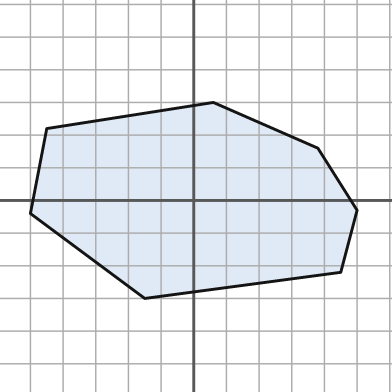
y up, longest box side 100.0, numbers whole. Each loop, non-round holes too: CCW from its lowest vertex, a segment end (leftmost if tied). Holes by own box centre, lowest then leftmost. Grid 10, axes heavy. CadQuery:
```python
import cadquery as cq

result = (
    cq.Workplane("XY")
    .moveTo(-15.0, -30.0)
    .lineTo(45.0, -22.0)
    .lineTo(50.0, -3.0)
    .lineTo(38.0, 16.0)
    .lineTo(6.0, 30.0)
    .lineTo(-45.0, 22.0)
    .lineTo(-50.0, -4.0)
    .close()
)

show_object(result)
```